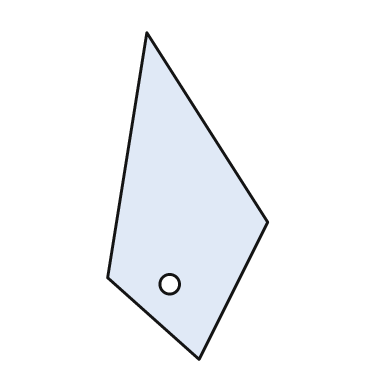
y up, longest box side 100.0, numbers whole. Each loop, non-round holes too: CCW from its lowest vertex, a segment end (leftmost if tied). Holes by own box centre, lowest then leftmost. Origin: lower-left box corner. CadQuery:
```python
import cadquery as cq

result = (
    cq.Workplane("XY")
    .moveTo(28.0, 0.0)
    .lineTo(49.0, 42.0)
    .lineTo(12.0, 100.0)
    .lineTo(0.0, 25.0)
    .close()
    .moveTo(19.0, 23.0)
    .circle(3.0)
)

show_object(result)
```